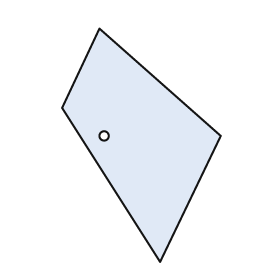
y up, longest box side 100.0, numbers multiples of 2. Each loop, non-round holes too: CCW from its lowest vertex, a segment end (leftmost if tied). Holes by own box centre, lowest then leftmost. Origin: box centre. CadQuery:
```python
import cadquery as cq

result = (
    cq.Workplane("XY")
    .moveTo(8.0, -50.0)
    .lineTo(34.0, 4.0)
    .lineTo(-18.0, 50.0)
    .lineTo(-34.0, 16.0)
    .close()
    .moveTo(-16.0, 4.0)
    .circle(2.0)
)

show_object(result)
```